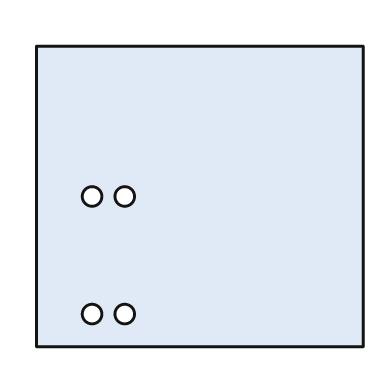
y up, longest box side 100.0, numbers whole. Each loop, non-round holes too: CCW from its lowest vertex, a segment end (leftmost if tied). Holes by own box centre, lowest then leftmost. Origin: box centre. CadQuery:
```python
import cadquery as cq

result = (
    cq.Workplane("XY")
    .moveTo(-50.0, -46.0)
    .lineTo(50.0, -46.0)
    .lineTo(50.0, 46.0)
    .lineTo(-50.0, 46.0)
    .close()
    .moveTo(-33.0, -36.0)
    .circle(3.0)
    .moveTo(-23.0, -36.0)
    .circle(3.0)
    .moveTo(-33.0, 0.0)
    .circle(3.0)
    .moveTo(-23.0, 0.0)
    .circle(3.0)
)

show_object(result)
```